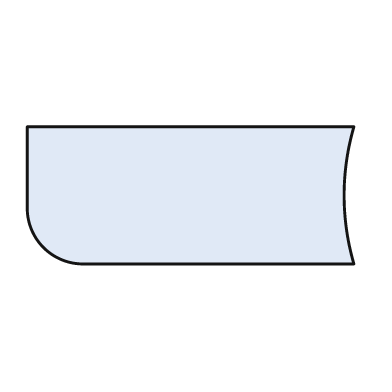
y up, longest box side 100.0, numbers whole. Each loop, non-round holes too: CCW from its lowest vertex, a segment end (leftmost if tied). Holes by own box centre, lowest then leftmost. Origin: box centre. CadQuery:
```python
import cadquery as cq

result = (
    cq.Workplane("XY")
    .moveTo(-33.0, -21.0)
    .lineTo(50.0, -21.0)
    .threePointArc((47.0, 0.0), (50.0, 21.0))
    .lineTo(-50.0, 21.0)
    .lineTo(-50.0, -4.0)
    .threePointArc((-45.0, -16.0), (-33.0, -21.0))
    .close()
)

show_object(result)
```